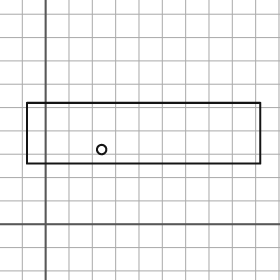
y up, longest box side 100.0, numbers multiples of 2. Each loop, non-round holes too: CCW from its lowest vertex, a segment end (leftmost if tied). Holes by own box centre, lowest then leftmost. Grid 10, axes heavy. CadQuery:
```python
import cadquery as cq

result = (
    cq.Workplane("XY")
    .moveTo(-8.0, 26.0)
    .lineTo(92.0, 26.0)
    .lineTo(92.0, 52.0)
    .lineTo(-8.0, 52.0)
    .close()
    .moveTo(24.0, 32.0)
    .circle(2.0)
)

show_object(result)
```